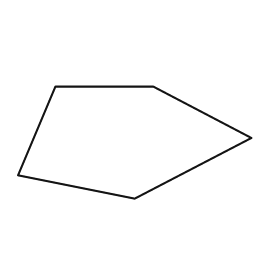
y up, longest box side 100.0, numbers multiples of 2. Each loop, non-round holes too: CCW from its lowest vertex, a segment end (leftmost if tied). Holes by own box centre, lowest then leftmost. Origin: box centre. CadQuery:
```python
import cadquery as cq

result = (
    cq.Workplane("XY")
    .moveTo(0.0, -24.0)
    .lineTo(50.0, 2.0)
    .lineTo(8.0, 24.0)
    .lineTo(-34.0, 24.0)
    .lineTo(-50.0, -14.0)
    .close()
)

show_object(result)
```